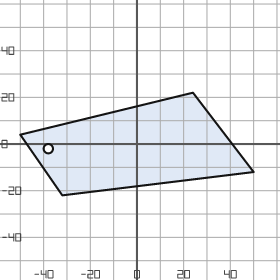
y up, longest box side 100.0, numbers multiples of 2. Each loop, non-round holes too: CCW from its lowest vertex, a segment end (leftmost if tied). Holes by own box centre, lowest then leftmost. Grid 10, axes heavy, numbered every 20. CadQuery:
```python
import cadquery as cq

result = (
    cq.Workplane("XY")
    .moveTo(-32.0, -22.0)
    .lineTo(50.0, -12.0)
    .lineTo(24.0, 22.0)
    .lineTo(-50.0, 4.0)
    .close()
    .moveTo(-38.0, -2.0)
    .circle(2.0)
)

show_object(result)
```